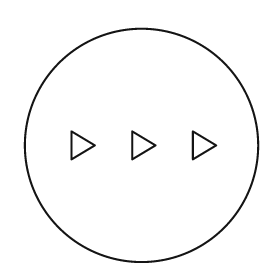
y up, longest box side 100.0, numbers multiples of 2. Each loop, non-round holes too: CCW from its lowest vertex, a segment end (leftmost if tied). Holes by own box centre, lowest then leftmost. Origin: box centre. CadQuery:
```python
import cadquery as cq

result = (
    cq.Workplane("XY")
    .moveTo(0.0, 0.0)
    .circle(50.0)
    .moveTo(-30.0, -6.0)
    .lineTo(-20.0, 0.0)
    .lineTo(-30.0, 6.0)
    .close()
    .moveTo(-4.0, -6.0)
    .lineTo(6.0, 0.0)
    .lineTo(-4.0, 6.0)
    .close()
    .moveTo(22.0, -6.0)
    .lineTo(32.0, 0.0)
    .lineTo(22.0, 6.0)
    .close()
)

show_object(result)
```